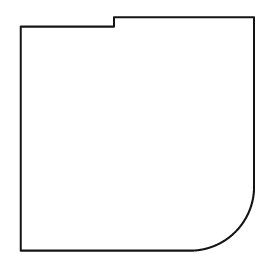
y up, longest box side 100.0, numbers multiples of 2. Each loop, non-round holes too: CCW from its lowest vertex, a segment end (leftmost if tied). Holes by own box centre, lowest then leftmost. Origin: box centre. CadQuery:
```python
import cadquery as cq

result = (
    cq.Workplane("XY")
    .moveTo(-50.0, -50.0)
    .lineTo(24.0, -50.0)
    .threePointArc((42.0, -42.0), (50.0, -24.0))
    .lineTo(50.0, 50.0)
    .lineTo(-10.0, 50.0)
    .lineTo(-10.0, 46.0)
    .lineTo(-50.0, 46.0)
    .close()
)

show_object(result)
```